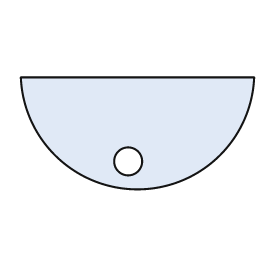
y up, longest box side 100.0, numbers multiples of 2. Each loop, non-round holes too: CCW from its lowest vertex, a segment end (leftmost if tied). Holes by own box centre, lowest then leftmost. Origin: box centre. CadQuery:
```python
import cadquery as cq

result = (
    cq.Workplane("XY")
    .moveTo(-50.0, 24.0)
    .threePointArc((0.0, -24.0), (50.0, 24.0))
    .close()
    .moveTo(-4.0, -12.0)
    .circle(6.0)
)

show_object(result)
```